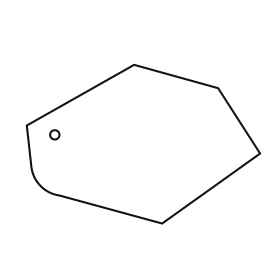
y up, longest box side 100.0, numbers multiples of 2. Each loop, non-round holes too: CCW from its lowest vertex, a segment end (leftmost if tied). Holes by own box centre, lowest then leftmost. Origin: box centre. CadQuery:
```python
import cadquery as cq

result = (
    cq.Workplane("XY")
    .moveTo(8.0, -34.0)
    .lineTo(50.0, -4.0)
    .lineTo(32.0, 24.0)
    .lineTo(-4.0, 34.0)
    .lineTo(-50.0, 8.0)
    .lineTo(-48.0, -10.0)
    .threePointArc((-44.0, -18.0), (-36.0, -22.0))
    .close()
    .moveTo(-38.0, 4.0)
    .circle(2.0)
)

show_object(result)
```